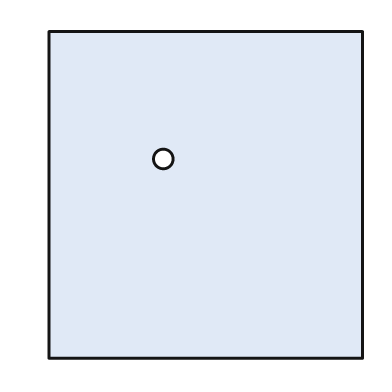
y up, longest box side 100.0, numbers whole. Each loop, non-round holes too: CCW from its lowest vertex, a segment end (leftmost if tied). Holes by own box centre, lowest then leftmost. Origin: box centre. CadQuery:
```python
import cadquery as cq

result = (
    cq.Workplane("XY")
    .moveTo(-48.0, -50.0)
    .lineTo(48.0, -50.0)
    .lineTo(48.0, 50.0)
    .lineTo(-48.0, 50.0)
    .close()
    .moveTo(-13.0, 11.0)
    .circle(3.0)
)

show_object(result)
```